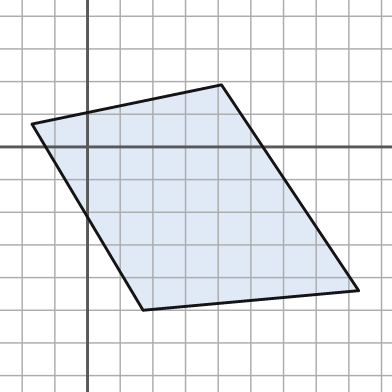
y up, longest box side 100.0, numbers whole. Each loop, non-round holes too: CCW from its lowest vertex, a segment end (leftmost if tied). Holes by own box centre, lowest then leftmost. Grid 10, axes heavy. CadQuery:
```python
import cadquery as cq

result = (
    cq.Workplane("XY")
    .moveTo(17.0, -50.0)
    .lineTo(83.0, -44.0)
    .lineTo(41.0, 19.0)
    .lineTo(-17.0, 7.0)
    .close()
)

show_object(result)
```